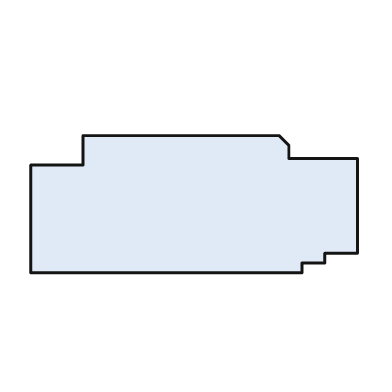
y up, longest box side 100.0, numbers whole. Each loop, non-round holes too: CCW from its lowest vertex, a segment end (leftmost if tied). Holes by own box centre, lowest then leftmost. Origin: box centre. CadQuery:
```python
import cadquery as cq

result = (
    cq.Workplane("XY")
    .moveTo(-50.0, -21.0)
    .lineTo(33.0, -21.0)
    .lineTo(33.0, -18.0)
    .lineTo(40.0, -18.0)
    .lineTo(40.0, -15.0)
    .lineTo(50.0, -15.0)
    .lineTo(50.0, 14.0)
    .lineTo(29.0, 14.0)
    .lineTo(29.0, 18.0)
    .lineTo(26.0, 21.0)
    .lineTo(-34.0, 21.0)
    .lineTo(-34.0, 12.0)
    .lineTo(-50.0, 12.0)
    .close()
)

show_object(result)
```